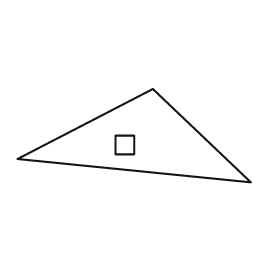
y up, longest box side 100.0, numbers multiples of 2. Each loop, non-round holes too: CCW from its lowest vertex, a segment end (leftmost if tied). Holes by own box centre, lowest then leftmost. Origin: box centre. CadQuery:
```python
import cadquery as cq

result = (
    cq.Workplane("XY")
    .moveTo(50.0, -20.0)
    .lineTo(8.0, 20.0)
    .lineTo(-50.0, -10.0)
    .close()
    .moveTo(-8.0, -8.0)
    .lineTo(0.0, -8.0)
    .lineTo(0.0, 0.0)
    .lineTo(-8.0, 0.0)
    .close()
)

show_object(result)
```